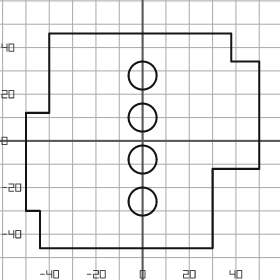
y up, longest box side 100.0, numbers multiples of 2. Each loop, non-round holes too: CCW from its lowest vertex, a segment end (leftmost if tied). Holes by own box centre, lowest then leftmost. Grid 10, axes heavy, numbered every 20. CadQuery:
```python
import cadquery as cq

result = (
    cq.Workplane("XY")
    .moveTo(-44.0, -46.0)
    .lineTo(30.0, -46.0)
    .lineTo(30.0, -12.0)
    .lineTo(50.0, -12.0)
    .lineTo(50.0, 34.0)
    .lineTo(38.0, 34.0)
    .lineTo(38.0, 46.0)
    .lineTo(-40.0, 46.0)
    .lineTo(-40.0, 12.0)
    .lineTo(-50.0, 12.0)
    .lineTo(-50.0, -30.0)
    .lineTo(-44.0, -30.0)
    .close()
    .moveTo(0.0, -26.0)
    .circle(6.0)
    .moveTo(0.0, -8.0)
    .circle(6.0)
    .moveTo(0.0, 10.0)
    .circle(6.0)
    .moveTo(0.0, 28.0)
    .circle(6.0)
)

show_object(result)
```